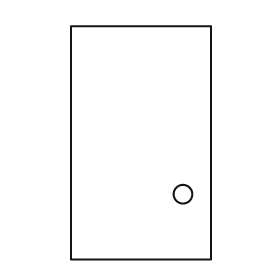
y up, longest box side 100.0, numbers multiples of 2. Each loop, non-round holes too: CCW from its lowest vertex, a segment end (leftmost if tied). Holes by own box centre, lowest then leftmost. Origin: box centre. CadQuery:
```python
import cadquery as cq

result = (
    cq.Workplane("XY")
    .moveTo(-30.0, -50.0)
    .lineTo(30.0, -50.0)
    .lineTo(30.0, 50.0)
    .lineTo(-30.0, 50.0)
    .close()
    .moveTo(18.0, -22.0)
    .circle(4.0)
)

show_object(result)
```